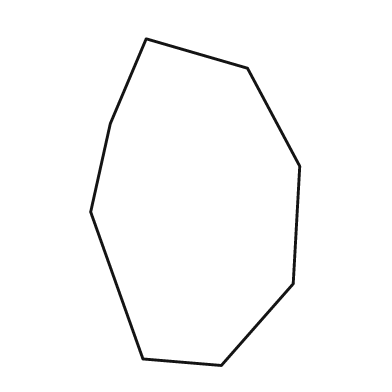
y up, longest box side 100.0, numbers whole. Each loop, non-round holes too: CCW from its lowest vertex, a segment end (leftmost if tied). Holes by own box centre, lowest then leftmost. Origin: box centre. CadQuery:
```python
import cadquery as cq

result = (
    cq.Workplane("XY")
    .moveTo(8.0, -50.0)
    .lineTo(30.0, -25.0)
    .lineTo(32.0, 11.0)
    .lineTo(16.0, 41.0)
    .lineTo(-15.0, 50.0)
    .lineTo(-26.0, 24.0)
    .lineTo(-32.0, -3.0)
    .lineTo(-16.0, -48.0)
    .close()
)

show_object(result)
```